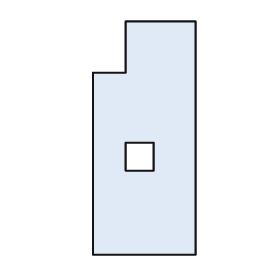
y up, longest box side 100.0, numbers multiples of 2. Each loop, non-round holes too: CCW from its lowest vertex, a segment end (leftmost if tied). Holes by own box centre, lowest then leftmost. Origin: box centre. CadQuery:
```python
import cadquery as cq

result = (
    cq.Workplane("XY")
    .moveTo(-22.0, -50.0)
    .lineTo(22.0, -50.0)
    .lineTo(22.0, 50.0)
    .lineTo(-8.0, 50.0)
    .lineTo(-8.0, 28.0)
    .lineTo(-22.0, 28.0)
    .close()
    .moveTo(-8.0, -14.0)
    .lineTo(4.0, -14.0)
    .lineTo(4.0, -2.0)
    .lineTo(-8.0, -2.0)
    .close()
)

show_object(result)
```